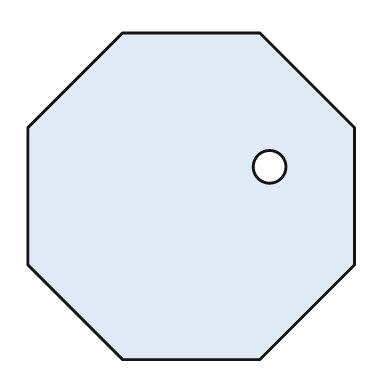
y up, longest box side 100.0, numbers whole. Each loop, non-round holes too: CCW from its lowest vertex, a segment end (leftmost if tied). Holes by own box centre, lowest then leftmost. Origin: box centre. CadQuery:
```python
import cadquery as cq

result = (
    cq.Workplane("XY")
    .moveTo(-21.0, -50.0)
    .lineTo(21.0, -50.0)
    .lineTo(50.0, -21.0)
    .lineTo(50.0, 21.0)
    .lineTo(21.0, 50.0)
    .lineTo(-21.0, 50.0)
    .lineTo(-50.0, 21.0)
    .lineTo(-50.0, -21.0)
    .close()
    .moveTo(24.0, 9.0)
    .circle(5.0)
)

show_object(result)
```